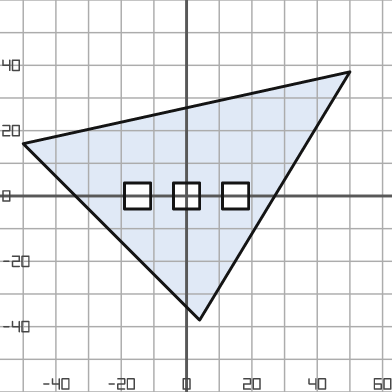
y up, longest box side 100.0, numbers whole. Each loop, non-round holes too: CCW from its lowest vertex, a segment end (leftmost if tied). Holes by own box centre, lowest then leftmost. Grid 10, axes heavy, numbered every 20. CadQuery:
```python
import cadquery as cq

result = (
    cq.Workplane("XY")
    .moveTo(4.0, -38.0)
    .lineTo(50.0, 38.0)
    .lineTo(-50.0, 16.0)
    .close()
    .moveTo(-19.0, -4.0)
    .lineTo(-11.0, -4.0)
    .lineTo(-11.0, 4.0)
    .lineTo(-19.0, 4.0)
    .close()
    .moveTo(-4.0, -4.0)
    .lineTo(4.0, -4.0)
    .lineTo(4.0, 4.0)
    .lineTo(-4.0, 4.0)
    .close()
    .moveTo(11.0, -4.0)
    .lineTo(19.0, -4.0)
    .lineTo(19.0, 4.0)
    .lineTo(11.0, 4.0)
    .close()
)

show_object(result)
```